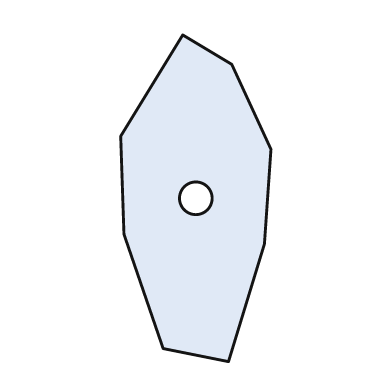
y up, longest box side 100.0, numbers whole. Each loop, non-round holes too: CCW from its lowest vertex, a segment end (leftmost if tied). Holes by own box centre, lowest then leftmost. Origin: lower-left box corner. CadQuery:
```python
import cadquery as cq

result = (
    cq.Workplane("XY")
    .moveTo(33.0, 0.0)
    .lineTo(44.0, 36.0)
    .lineTo(46.0, 65.0)
    .lineTo(34.0, 91.0)
    .lineTo(19.0, 100.0)
    .lineTo(0.0, 69.0)
    .lineTo(1.0, 39.0)
    .lineTo(13.0, 4.0)
    .close()
    .moveTo(23.0, 50.0)
    .circle(5.0)
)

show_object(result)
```